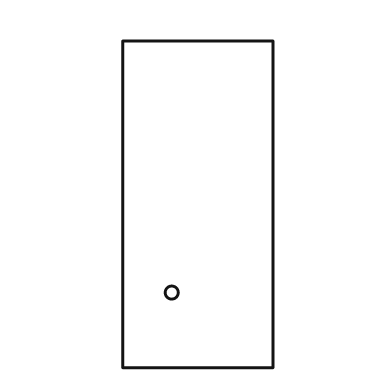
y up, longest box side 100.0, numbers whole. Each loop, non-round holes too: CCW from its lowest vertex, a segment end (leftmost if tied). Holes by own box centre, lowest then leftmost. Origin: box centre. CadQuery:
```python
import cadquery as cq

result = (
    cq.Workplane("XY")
    .moveTo(-23.0, -50.0)
    .lineTo(23.0, -50.0)
    .lineTo(23.0, 50.0)
    .lineTo(-23.0, 50.0)
    .close()
    .moveTo(-8.0, -27.0)
    .circle(2.0)
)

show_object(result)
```